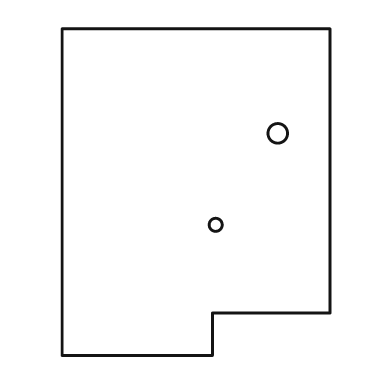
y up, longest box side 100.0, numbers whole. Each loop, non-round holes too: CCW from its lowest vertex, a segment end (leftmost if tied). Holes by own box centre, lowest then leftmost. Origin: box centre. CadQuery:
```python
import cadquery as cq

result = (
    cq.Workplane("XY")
    .moveTo(-41.0, -50.0)
    .lineTo(5.0, -50.0)
    .lineTo(5.0, -37.0)
    .lineTo(41.0, -37.0)
    .lineTo(41.0, 50.0)
    .lineTo(-41.0, 50.0)
    .close()
    .moveTo(6.0, -10.0)
    .circle(2.0)
    .moveTo(25.0, 18.0)
    .circle(3.0)
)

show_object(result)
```